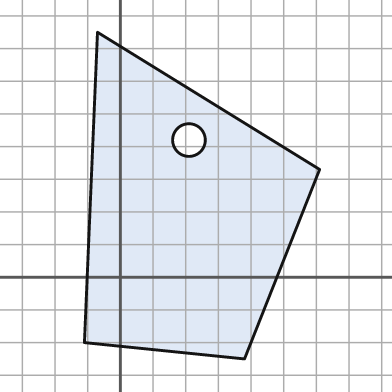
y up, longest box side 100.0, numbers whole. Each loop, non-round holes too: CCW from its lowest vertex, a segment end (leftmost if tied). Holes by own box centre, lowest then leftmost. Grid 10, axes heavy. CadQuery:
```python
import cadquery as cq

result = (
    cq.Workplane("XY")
    .moveTo(38.0, -25.0)
    .lineTo(61.0, 33.0)
    .lineTo(-7.0, 75.0)
    .lineTo(-11.0, -20.0)
    .close()
    .moveTo(21.0, 42.0)
    .circle(5.0)
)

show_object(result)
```